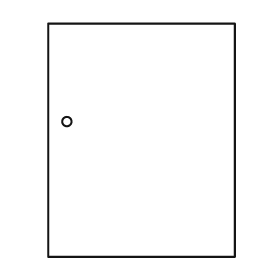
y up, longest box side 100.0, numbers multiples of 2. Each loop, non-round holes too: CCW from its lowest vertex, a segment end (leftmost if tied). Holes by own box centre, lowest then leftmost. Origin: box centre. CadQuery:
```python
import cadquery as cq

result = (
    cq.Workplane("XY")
    .moveTo(-40.0, -50.0)
    .lineTo(40.0, -50.0)
    .lineTo(40.0, 50.0)
    .lineTo(-40.0, 50.0)
    .close()
    .moveTo(-32.0, 8.0)
    .circle(2.0)
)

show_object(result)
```